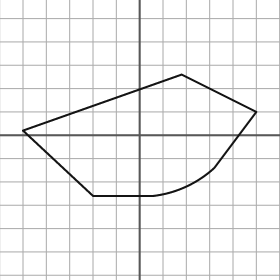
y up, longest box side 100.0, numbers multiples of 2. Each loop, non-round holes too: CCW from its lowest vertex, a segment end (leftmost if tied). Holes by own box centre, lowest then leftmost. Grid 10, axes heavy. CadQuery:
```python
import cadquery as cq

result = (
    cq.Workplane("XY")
    .moveTo(-20.0, -26.0)
    .lineTo(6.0, -26.0)
    .threePointArc((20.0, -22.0), (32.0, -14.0))
    .lineTo(50.0, 10.0)
    .lineTo(18.0, 26.0)
    .lineTo(-50.0, 2.0)
    .close()
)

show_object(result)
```